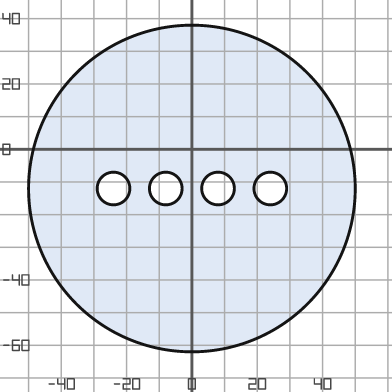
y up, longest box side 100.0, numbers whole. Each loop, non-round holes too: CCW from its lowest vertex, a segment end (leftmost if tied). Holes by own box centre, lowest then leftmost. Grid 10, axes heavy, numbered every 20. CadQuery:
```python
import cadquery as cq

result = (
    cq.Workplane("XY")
    .moveTo(0.0, -12.0)
    .circle(50.0)
    .moveTo(-24.0, -12.0)
    .circle(5.0)
    .moveTo(-8.0, -12.0)
    .circle(5.0)
    .moveTo(8.0, -12.0)
    .circle(5.0)
    .moveTo(24.0, -12.0)
    .circle(5.0)
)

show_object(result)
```